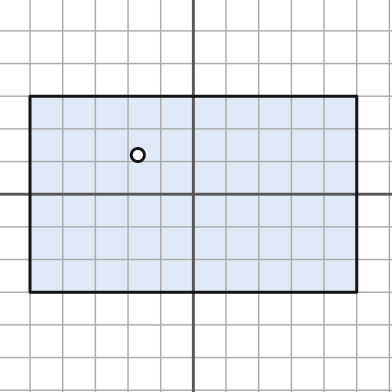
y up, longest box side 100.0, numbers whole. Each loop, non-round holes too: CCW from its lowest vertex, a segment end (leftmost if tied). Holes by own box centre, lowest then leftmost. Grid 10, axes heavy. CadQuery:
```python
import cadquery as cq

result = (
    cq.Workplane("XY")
    .moveTo(-50.0, -30.0)
    .lineTo(50.0, -30.0)
    .lineTo(50.0, 30.0)
    .lineTo(-50.0, 30.0)
    .close()
    .moveTo(-17.0, 12.0)
    .circle(2.0)
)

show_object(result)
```